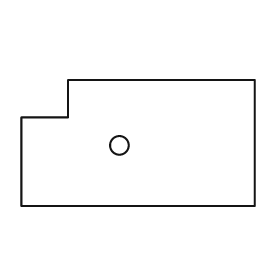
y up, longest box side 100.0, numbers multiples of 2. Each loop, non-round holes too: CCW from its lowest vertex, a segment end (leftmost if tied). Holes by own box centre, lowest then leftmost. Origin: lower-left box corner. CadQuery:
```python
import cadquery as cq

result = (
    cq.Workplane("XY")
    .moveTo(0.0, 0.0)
    .lineTo(100.0, 0.0)
    .lineTo(100.0, 54.0)
    .lineTo(20.0, 54.0)
    .lineTo(20.0, 38.0)
    .lineTo(0.0, 38.0)
    .close()
    .moveTo(42.0, 26.0)
    .circle(4.0)
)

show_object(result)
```